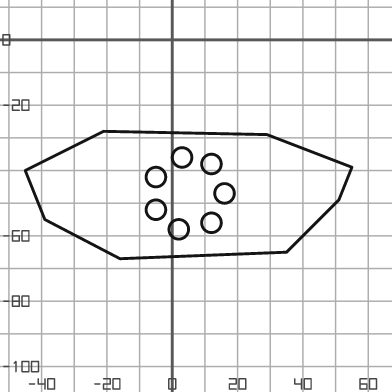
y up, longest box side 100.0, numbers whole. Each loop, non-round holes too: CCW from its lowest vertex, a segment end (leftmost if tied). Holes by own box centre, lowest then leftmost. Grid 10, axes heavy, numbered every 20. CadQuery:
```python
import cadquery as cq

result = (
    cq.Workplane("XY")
    .moveTo(-16.0, -67.0)
    .lineTo(35.0, -65.0)
    .lineTo(51.0, -49.0)
    .lineTo(55.0, -39.0)
    .lineTo(29.0, -29.0)
    .lineTo(-21.0, -28.0)
    .lineTo(-45.0, -40.0)
    .lineTo(-39.0, -55.0)
    .close()
    .moveTo(2.0, -58.0)
    .circle(3.0)
    .moveTo(12.0, -56.0)
    .circle(3.0)
    .moveTo(-5.0, -52.0)
    .circle(3.0)
    .moveTo(16.0, -47.0)
    .circle(3.0)
    .moveTo(-5.0, -42.0)
    .circle(3.0)
    .moveTo(12.0, -38.0)
    .circle(3.0)
    .moveTo(3.0, -36.0)
    .circle(3.0)
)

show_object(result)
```